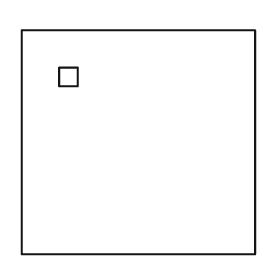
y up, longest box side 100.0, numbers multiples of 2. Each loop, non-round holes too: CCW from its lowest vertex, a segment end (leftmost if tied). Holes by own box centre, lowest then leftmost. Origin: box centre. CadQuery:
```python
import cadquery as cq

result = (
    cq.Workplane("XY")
    .moveTo(-50.0, -48.0)
    .lineTo(50.0, -48.0)
    .lineTo(50.0, 48.0)
    .lineTo(-50.0, 48.0)
    .close()
    .moveTo(-34.0, 24.0)
    .lineTo(-26.0, 24.0)
    .lineTo(-26.0, 32.0)
    .lineTo(-34.0, 32.0)
    .close()
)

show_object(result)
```